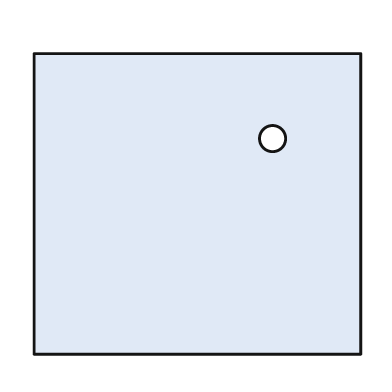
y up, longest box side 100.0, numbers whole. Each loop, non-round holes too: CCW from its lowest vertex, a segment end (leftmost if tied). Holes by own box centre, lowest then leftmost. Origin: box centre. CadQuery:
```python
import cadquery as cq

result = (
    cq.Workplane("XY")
    .moveTo(-50.0, -46.0)
    .lineTo(50.0, -46.0)
    .lineTo(50.0, 46.0)
    .lineTo(-50.0, 46.0)
    .close()
    .moveTo(23.0, 20.0)
    .circle(4.0)
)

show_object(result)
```